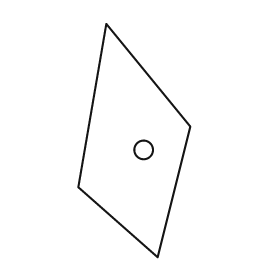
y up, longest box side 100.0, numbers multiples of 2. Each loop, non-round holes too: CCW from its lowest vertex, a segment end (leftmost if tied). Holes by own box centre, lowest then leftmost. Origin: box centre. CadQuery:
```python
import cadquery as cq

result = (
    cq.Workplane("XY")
    .moveTo(10.0, -50.0)
    .lineTo(24.0, 6.0)
    .lineTo(-12.0, 50.0)
    .lineTo(-24.0, -20.0)
    .close()
    .moveTo(4.0, -4.0)
    .circle(4.0)
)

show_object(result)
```